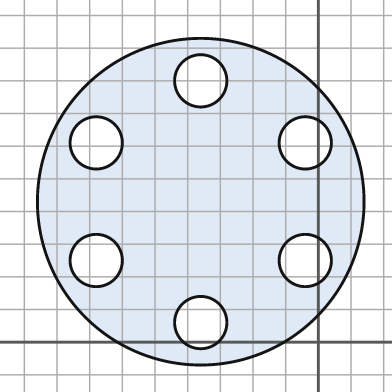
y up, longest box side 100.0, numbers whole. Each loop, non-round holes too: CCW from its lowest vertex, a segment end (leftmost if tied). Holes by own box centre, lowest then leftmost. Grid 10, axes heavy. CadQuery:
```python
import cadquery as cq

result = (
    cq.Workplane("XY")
    .moveTo(-36.0, 43.0)
    .circle(50.0)
    .moveTo(-36.0, 6.0)
    .circle(8.0)
    .moveTo(-68.0, 25.0)
    .circle(8.0)
    .moveTo(-4.0, 25.0)
    .circle(8.0)
    .moveTo(-68.0, 61.0)
    .circle(8.0)
    .moveTo(-4.0, 61.0)
    .circle(8.0)
    .moveTo(-36.0, 80.0)
    .circle(8.0)
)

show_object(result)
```